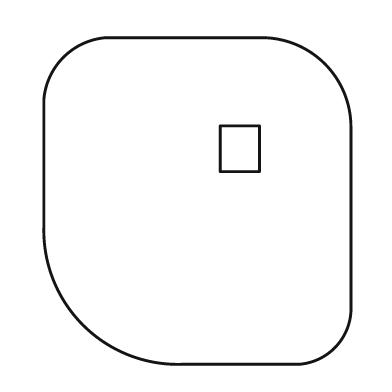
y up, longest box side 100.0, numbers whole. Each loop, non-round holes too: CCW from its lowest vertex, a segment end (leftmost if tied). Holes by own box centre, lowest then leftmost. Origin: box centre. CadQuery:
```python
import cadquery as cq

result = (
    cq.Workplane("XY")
    .moveTo(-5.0, -50.0)
    .lineTo(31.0, -50.0)
    .threePointArc((42.0, -45.0), (47.0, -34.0))
    .lineTo(47.0, 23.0)
    .threePointArc((39.0, 42.0), (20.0, 50.0))
    .lineTo(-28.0, 50.0)
    .threePointArc((-41.0, 44.0), (-47.0, 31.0))
    .lineTo(-47.0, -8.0)
    .threePointArc((-35.0, -38.0), (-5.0, -50.0))
    .close()
    .moveTo(7.0, 9.0)
    .lineTo(19.0, 9.0)
    .lineTo(19.0, 23.0)
    .lineTo(7.0, 23.0)
    .close()
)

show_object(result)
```